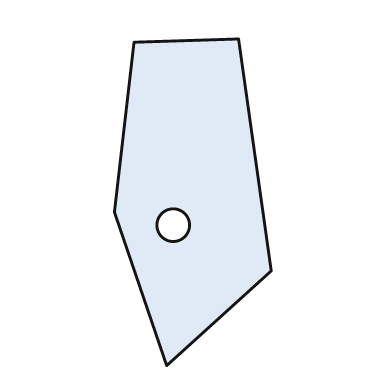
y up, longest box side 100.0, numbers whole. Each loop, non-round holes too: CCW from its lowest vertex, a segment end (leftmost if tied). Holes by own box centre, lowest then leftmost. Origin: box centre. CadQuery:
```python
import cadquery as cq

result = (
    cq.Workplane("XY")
    .moveTo(-8.0, -50.0)
    .lineTo(24.0, -21.0)
    .lineTo(14.0, 50.0)
    .lineTo(-18.0, 49.0)
    .lineTo(-24.0, -3.0)
    .close()
    .moveTo(-6.0, -7.0)
    .circle(5.0)
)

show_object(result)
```